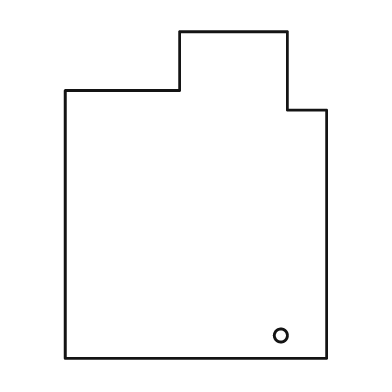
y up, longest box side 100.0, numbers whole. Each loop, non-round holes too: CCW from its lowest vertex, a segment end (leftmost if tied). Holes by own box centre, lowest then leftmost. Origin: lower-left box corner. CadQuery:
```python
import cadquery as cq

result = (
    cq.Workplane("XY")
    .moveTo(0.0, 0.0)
    .lineTo(80.0, 0.0)
    .lineTo(80.0, 76.0)
    .lineTo(68.0, 76.0)
    .lineTo(68.0, 100.0)
    .lineTo(35.0, 100.0)
    .lineTo(35.0, 82.0)
    .lineTo(0.0, 82.0)
    .close()
    .moveTo(66.0, 7.0)
    .circle(2.0)
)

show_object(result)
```